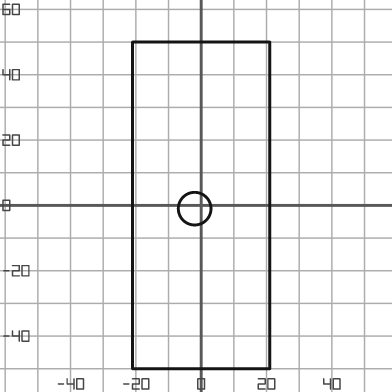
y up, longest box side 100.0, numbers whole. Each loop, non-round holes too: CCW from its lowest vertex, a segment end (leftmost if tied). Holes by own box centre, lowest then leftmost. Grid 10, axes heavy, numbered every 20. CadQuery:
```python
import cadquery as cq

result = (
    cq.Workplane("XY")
    .moveTo(-21.0, -50.0)
    .lineTo(21.0, -50.0)
    .lineTo(21.0, 50.0)
    .lineTo(-21.0, 50.0)
    .close()
    .moveTo(-2.0, -1.0)
    .circle(5.0)
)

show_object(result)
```